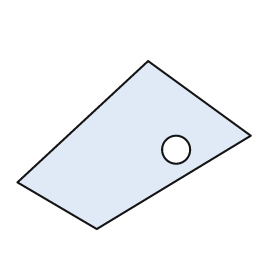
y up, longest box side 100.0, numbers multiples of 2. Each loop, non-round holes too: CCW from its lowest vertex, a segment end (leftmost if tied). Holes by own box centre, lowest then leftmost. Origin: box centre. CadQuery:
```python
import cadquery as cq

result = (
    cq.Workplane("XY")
    .moveTo(-16.0, -36.0)
    .lineTo(50.0, 4.0)
    .lineTo(6.0, 36.0)
    .lineTo(-50.0, -16.0)
    .close()
    .moveTo(18.0, -2.0)
    .circle(6.0)
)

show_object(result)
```